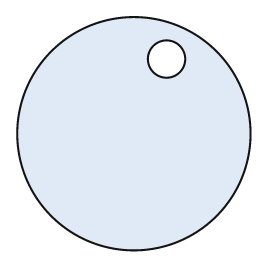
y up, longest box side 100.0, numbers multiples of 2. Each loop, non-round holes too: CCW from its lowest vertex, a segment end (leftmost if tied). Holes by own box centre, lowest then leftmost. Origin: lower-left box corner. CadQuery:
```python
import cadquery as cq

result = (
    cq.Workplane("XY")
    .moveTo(50.0, 50.0)
    .circle(50.0)
    .moveTo(64.0, 82.0)
    .circle(8.0)
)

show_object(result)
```